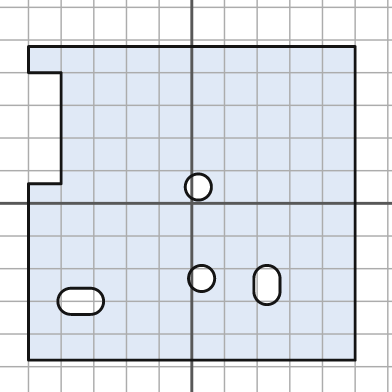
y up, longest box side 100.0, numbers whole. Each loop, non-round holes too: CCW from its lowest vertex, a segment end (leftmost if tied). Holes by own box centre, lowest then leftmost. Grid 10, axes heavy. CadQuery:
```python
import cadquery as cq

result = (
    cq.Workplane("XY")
    .moveTo(-50.0, -48.0)
    .lineTo(50.0, -48.0)
    .lineTo(50.0, 48.0)
    .lineTo(-50.0, 48.0)
    .lineTo(-50.0, 40.0)
    .lineTo(-40.0, 40.0)
    .lineTo(-40.0, 6.0)
    .lineTo(-50.0, 6.0)
    .close()
    .moveTo(-37.0, -34.0)
    .lineTo(-31.0, -34.0)
    .threePointArc((-27.0, -30.0), (-31.0, -26.0))
    .lineTo(-37.0, -26.0)
    .threePointArc((-41.0, -30.0), (-37.0, -34.0))
    .close()
    .moveTo(19.0, -27.0)
    .threePointArc((23.0, -31.0), (27.0, -27.0))
    .lineTo(27.0, -23.0)
    .threePointArc((23.0, -19.0), (19.0, -23.0))
    .close()
    .moveTo(3.0, -23.0)
    .circle(4.0)
    .moveTo(2.0, 5.0)
    .circle(4.0)
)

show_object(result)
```